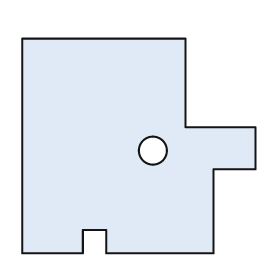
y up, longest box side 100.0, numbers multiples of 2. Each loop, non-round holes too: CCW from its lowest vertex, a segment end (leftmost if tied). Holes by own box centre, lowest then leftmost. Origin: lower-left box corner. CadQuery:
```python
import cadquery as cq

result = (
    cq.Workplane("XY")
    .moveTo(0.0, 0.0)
    .lineTo(26.0, 0.0)
    .lineTo(26.0, 10.0)
    .lineTo(36.0, 10.0)
    .lineTo(36.0, 0.0)
    .lineTo(82.0, 0.0)
    .lineTo(82.0, 36.0)
    .lineTo(100.0, 36.0)
    .lineTo(100.0, 54.0)
    .lineTo(70.0, 54.0)
    .lineTo(70.0, 92.0)
    .lineTo(0.0, 92.0)
    .close()
    .moveTo(56.0, 44.0)
    .circle(6.0)
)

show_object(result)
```